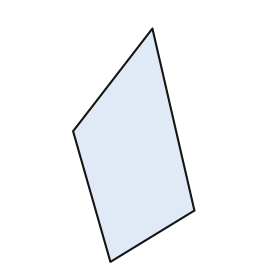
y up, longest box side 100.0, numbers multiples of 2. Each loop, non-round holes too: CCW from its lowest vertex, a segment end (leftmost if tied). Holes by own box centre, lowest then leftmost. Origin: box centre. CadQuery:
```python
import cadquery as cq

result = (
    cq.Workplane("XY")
    .moveTo(-10.0, -50.0)
    .lineTo(26.0, -28.0)
    .lineTo(8.0, 50.0)
    .lineTo(-26.0, 6.0)
    .close()
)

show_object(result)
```